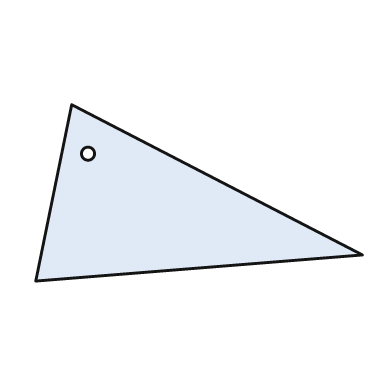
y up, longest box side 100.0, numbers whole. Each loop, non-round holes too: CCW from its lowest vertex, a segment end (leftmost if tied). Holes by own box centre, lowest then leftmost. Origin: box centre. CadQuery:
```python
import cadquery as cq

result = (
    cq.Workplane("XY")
    .moveTo(-50.0, -27.0)
    .lineTo(50.0, -19.0)
    .lineTo(-39.0, 27.0)
    .close()
    .moveTo(-34.0, 12.0)
    .circle(2.0)
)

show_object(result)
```